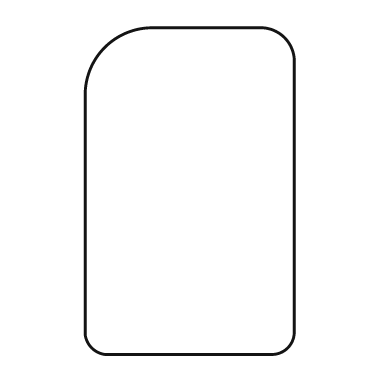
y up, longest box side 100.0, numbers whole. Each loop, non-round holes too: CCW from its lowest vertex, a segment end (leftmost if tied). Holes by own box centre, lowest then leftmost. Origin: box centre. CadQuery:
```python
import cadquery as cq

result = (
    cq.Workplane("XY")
    .moveTo(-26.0, -50.0)
    .lineTo(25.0, -50.0)
    .threePointArc((30.0, -48.0), (32.0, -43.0))
    .lineTo(32.0, 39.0)
    .threePointArc((29.0, 47.0), (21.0, 50.0))
    .lineTo(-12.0, 50.0)
    .threePointArc((-26.0, 44.0), (-32.0, 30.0))
    .lineTo(-32.0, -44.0)
    .threePointArc((-30.0, -48.0), (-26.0, -50.0))
    .close()
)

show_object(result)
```